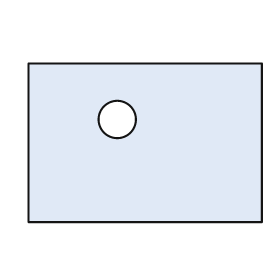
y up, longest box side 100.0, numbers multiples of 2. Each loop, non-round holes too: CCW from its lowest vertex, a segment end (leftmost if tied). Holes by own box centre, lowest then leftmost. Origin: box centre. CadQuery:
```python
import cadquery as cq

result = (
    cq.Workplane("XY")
    .moveTo(-50.0, -34.0)
    .lineTo(50.0, -34.0)
    .lineTo(50.0, 34.0)
    .lineTo(-50.0, 34.0)
    .close()
    .moveTo(-12.0, 10.0)
    .circle(8.0)
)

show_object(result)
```